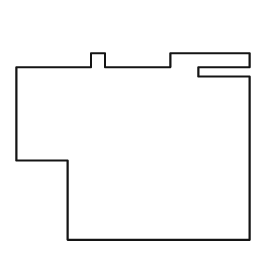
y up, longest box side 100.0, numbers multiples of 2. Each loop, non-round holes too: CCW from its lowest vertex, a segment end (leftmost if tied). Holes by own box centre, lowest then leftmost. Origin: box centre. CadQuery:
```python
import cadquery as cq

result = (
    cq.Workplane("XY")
    .moveTo(-28.0, -40.0)
    .lineTo(50.0, -40.0)
    .lineTo(50.0, 30.0)
    .lineTo(28.0, 30.0)
    .lineTo(28.0, 34.0)
    .lineTo(50.0, 34.0)
    .lineTo(50.0, 40.0)
    .lineTo(16.0, 40.0)
    .lineTo(16.0, 34.0)
    .lineTo(-12.0, 34.0)
    .lineTo(-12.0, 40.0)
    .lineTo(-18.0, 40.0)
    .lineTo(-18.0, 34.0)
    .lineTo(-50.0, 34.0)
    .lineTo(-50.0, -6.0)
    .lineTo(-28.0, -6.0)
    .close()
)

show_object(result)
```